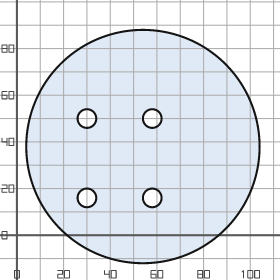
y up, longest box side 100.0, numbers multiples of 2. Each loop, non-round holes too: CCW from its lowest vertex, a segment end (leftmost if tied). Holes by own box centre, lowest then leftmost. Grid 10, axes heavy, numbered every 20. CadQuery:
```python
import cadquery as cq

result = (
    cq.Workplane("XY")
    .moveTo(54.0, 38.0)
    .circle(50.0)
    .moveTo(30.0, 16.0)
    .circle(4.0)
    .moveTo(58.0, 16.0)
    .circle(4.0)
    .moveTo(30.0, 50.0)
    .circle(4.0)
    .moveTo(58.0, 50.0)
    .circle(4.0)
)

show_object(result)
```